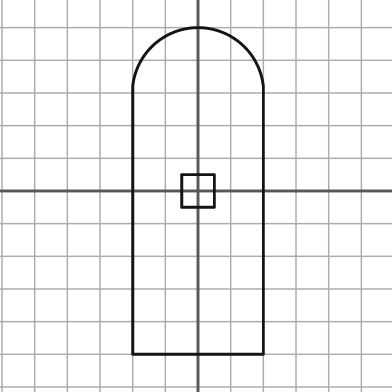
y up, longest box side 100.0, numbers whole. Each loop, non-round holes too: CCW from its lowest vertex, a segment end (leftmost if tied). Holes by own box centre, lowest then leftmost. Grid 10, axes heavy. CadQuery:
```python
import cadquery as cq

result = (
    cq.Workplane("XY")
    .moveTo(-20.0, -50.0)
    .lineTo(20.0, -50.0)
    .lineTo(20.0, 32.0)
    .threePointArc((0.0, 50.0), (-20.0, 32.0))
    .close()
    .moveTo(-5.0, -5.0)
    .lineTo(5.0, -5.0)
    .lineTo(5.0, 5.0)
    .lineTo(-5.0, 5.0)
    .close()
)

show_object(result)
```